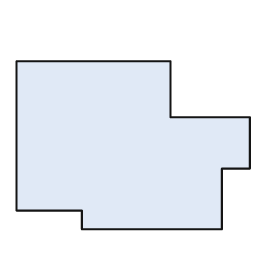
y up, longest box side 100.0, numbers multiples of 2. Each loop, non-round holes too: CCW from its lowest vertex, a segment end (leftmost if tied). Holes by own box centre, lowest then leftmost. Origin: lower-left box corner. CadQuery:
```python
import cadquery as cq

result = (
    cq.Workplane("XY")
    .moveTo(28.0, 0.0)
    .lineTo(88.0, 0.0)
    .lineTo(88.0, 26.0)
    .lineTo(100.0, 26.0)
    .lineTo(100.0, 48.0)
    .lineTo(66.0, 48.0)
    .lineTo(66.0, 72.0)
    .lineTo(0.0, 72.0)
    .lineTo(0.0, 8.0)
    .lineTo(28.0, 8.0)
    .close()
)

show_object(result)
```